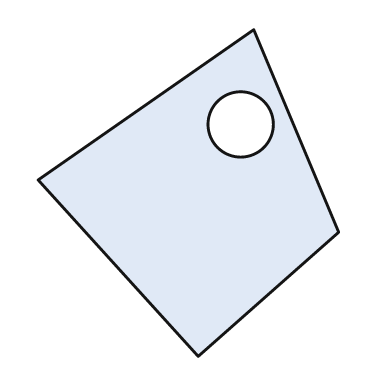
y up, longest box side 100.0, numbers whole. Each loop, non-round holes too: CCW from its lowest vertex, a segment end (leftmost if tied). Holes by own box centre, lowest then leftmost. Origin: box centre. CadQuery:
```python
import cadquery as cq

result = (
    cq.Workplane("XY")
    .moveTo(3.0, -50.0)
    .lineTo(46.0, -12.0)
    .lineTo(20.0, 50.0)
    .lineTo(-46.0, 4.0)
    .close()
    .moveTo(16.0, 21.0)
    .circle(10.0)
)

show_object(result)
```